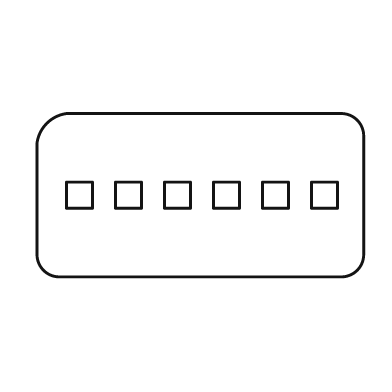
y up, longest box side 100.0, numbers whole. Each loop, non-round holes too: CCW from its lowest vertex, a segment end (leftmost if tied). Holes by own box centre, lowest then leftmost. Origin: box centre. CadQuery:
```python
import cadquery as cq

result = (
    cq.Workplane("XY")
    .moveTo(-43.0, -25.0)
    .lineTo(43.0, -25.0)
    .threePointArc((48.0, -23.0), (50.0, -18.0))
    .lineTo(50.0, 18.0)
    .threePointArc((48.0, 23.0), (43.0, 25.0))
    .lineTo(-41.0, 25.0)
    .threePointArc((-47.0, 22.0), (-50.0, 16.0))
    .lineTo(-50.0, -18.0)
    .threePointArc((-48.0, -23.0), (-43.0, -25.0))
    .close()
    .moveTo(-41.0, -4.0)
    .lineTo(-33.0, -4.0)
    .lineTo(-33.0, 4.0)
    .lineTo(-41.0, 4.0)
    .close()
    .moveTo(-26.0, -4.0)
    .lineTo(-18.0, -4.0)
    .lineTo(-18.0, 4.0)
    .lineTo(-26.0, 4.0)
    .close()
    .moveTo(-11.0, -4.0)
    .lineTo(-3.0, -4.0)
    .lineTo(-3.0, 4.0)
    .lineTo(-11.0, 4.0)
    .close()
    .moveTo(4.0, -4.0)
    .lineTo(12.0, -4.0)
    .lineTo(12.0, 4.0)
    .lineTo(4.0, 4.0)
    .close()
    .moveTo(19.0, -4.0)
    .lineTo(27.0, -4.0)
    .lineTo(27.0, 4.0)
    .lineTo(19.0, 4.0)
    .close()
    .moveTo(34.0, -4.0)
    .lineTo(42.0, -4.0)
    .lineTo(42.0, 4.0)
    .lineTo(34.0, 4.0)
    .close()
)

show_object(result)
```